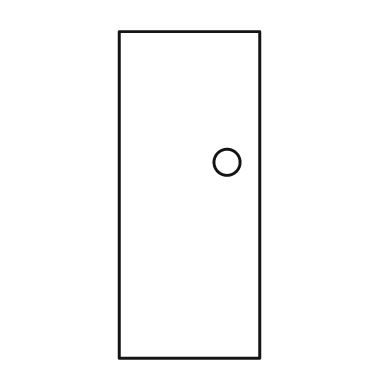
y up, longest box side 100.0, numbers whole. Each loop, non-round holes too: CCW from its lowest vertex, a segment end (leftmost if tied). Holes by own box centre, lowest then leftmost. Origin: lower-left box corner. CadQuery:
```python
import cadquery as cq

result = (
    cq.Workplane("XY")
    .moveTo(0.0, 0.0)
    .lineTo(43.0, 0.0)
    .lineTo(43.0, 100.0)
    .lineTo(0.0, 100.0)
    .close()
    .moveTo(33.0, 60.0)
    .circle(4.0)
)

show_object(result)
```